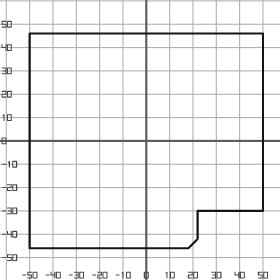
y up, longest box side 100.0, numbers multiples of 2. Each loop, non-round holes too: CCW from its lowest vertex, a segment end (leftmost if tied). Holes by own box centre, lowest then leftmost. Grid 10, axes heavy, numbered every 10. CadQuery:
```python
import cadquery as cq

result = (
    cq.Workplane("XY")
    .moveTo(-50.0, -46.0)
    .lineTo(18.0, -46.0)
    .lineTo(22.0, -42.0)
    .lineTo(22.0, -30.0)
    .lineTo(50.0, -30.0)
    .lineTo(50.0, 46.0)
    .lineTo(-50.0, 46.0)
    .close()
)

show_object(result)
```